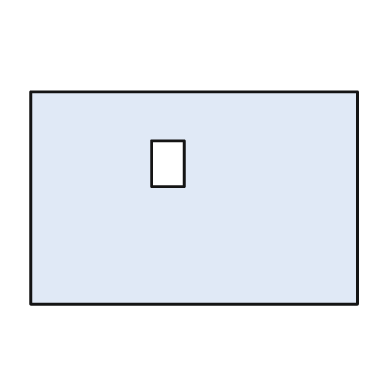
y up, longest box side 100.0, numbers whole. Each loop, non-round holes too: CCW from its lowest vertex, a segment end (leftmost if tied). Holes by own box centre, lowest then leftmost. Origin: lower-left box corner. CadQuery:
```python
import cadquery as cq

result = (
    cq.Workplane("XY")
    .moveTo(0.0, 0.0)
    .lineTo(100.0, 0.0)
    .lineTo(100.0, 65.0)
    .lineTo(0.0, 65.0)
    .close()
    .moveTo(37.0, 36.0)
    .lineTo(47.0, 36.0)
    .lineTo(47.0, 50.0)
    .lineTo(37.0, 50.0)
    .close()
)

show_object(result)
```